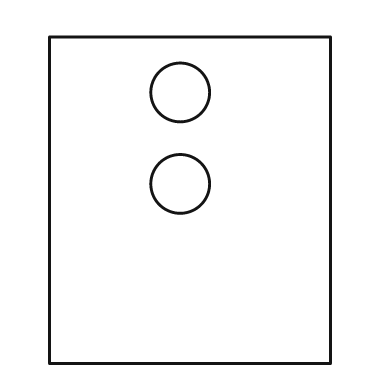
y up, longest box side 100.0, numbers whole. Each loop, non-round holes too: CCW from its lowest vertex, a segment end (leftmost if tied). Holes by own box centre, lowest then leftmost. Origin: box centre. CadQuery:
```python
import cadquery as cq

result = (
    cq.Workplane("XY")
    .moveTo(-43.0, -50.0)
    .lineTo(43.0, -50.0)
    .lineTo(43.0, 50.0)
    .lineTo(-43.0, 50.0)
    .close()
    .moveTo(-3.0, 5.0)
    .circle(9.0)
    .moveTo(-3.0, 33.0)
    .circle(9.0)
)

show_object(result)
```